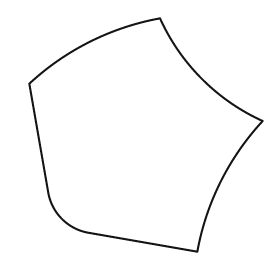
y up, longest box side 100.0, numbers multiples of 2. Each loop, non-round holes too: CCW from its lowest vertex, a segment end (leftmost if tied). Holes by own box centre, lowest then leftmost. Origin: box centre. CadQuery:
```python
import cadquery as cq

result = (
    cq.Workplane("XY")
    .moveTo(22.0, -50.0)
    .threePointArc((32.0, -20.0), (50.0, 6.0))
    .threePointArc((24.0, 24.0), (6.0, 50.0))
    .threePointArc((-24.0, 40.0), (-50.0, 22.0))
    .lineTo(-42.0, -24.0)
    .threePointArc((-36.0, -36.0), (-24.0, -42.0))
    .close()
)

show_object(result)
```